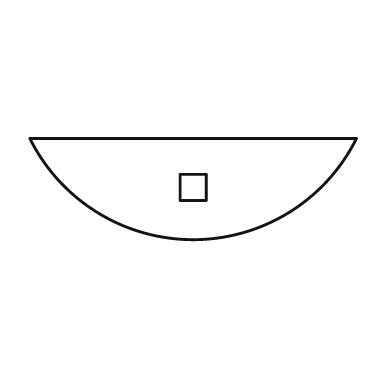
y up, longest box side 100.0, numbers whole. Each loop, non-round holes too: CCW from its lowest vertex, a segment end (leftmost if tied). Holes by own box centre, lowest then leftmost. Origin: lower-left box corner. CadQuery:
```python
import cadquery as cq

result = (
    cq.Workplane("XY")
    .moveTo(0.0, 31.0)
    .threePointArc((50.0, 0.0), (100.0, 31.0))
    .close()
    .moveTo(46.0, 12.0)
    .lineTo(54.0, 12.0)
    .lineTo(54.0, 20.0)
    .lineTo(46.0, 20.0)
    .close()
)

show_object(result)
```